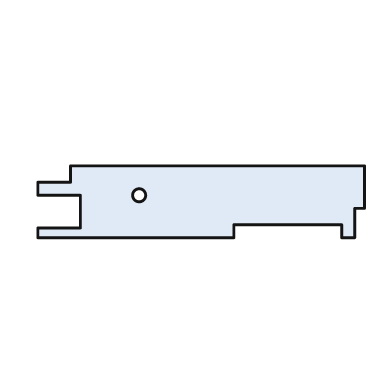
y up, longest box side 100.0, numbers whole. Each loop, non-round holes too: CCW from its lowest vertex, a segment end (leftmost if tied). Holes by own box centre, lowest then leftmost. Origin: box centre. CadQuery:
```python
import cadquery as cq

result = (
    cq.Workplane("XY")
    .moveTo(-50.0, -11.0)
    .lineTo(10.0, -11.0)
    .lineTo(10.0, -7.0)
    .lineTo(43.0, -7.0)
    .lineTo(43.0, -11.0)
    .lineTo(47.0, -11.0)
    .lineTo(47.0, -2.0)
    .lineTo(50.0, -2.0)
    .lineTo(50.0, 11.0)
    .lineTo(-40.0, 11.0)
    .lineTo(-40.0, 6.0)
    .lineTo(-50.0, 6.0)
    .lineTo(-50.0, 2.0)
    .lineTo(-37.0, 2.0)
    .lineTo(-37.0, -8.0)
    .lineTo(-50.0, -8.0)
    .close()
    .moveTo(-19.0, 2.0)
    .circle(2.0)
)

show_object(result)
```